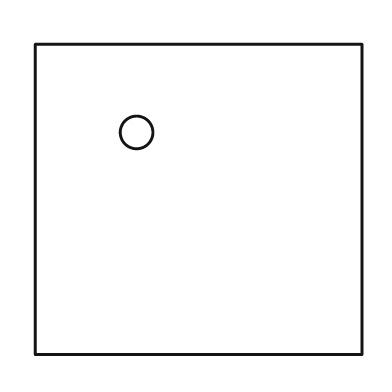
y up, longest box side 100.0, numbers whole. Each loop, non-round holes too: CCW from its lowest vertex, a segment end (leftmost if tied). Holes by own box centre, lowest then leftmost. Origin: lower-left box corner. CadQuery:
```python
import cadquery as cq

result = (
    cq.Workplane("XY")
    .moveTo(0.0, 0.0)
    .lineTo(100.0, 0.0)
    .lineTo(100.0, 95.0)
    .lineTo(0.0, 95.0)
    .close()
    .moveTo(31.0, 68.0)
    .circle(5.0)
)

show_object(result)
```